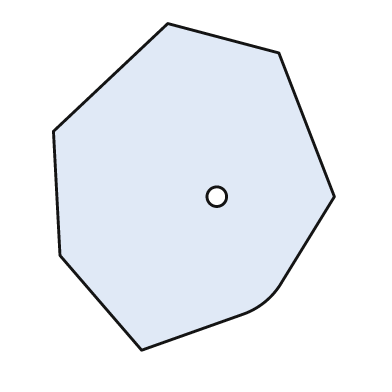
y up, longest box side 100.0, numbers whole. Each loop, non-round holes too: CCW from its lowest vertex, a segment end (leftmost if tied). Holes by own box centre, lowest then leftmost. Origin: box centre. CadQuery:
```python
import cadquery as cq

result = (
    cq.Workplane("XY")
    .moveTo(-16.0, -50.0)
    .lineTo(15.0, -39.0)
    .threePointArc((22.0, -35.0), (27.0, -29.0))
    .lineTo(43.0, -3.0)
    .lineTo(26.0, 41.0)
    .lineTo(-8.0, 50.0)
    .lineTo(-43.0, 17.0)
    .lineTo(-41.0, -21.0)
    .close()
    .moveTo(7.0, -3.0)
    .circle(3.0)
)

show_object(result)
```